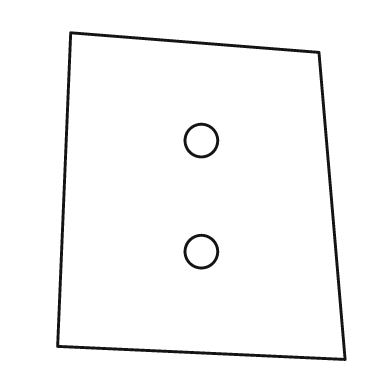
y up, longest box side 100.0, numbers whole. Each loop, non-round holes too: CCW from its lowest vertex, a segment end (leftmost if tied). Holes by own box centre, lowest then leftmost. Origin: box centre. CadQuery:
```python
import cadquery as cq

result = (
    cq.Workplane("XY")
    .moveTo(44.0, -50.0)
    .lineTo(36.0, 44.0)
    .lineTo(-40.0, 50.0)
    .lineTo(-44.0, -46.0)
    .close()
    .moveTo(0.0, -17.0)
    .circle(5.0)
    .moveTo(0.0, 17.0)
    .circle(5.0)
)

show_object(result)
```